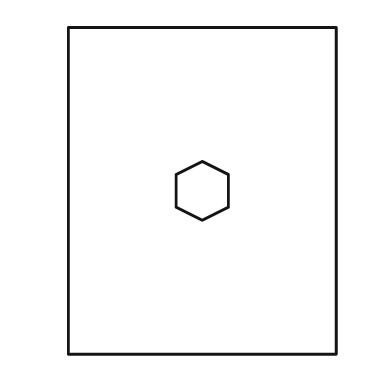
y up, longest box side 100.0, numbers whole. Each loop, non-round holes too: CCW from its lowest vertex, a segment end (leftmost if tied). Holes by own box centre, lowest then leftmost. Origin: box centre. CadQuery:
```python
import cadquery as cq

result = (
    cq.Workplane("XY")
    .moveTo(-41.0, -50.0)
    .lineTo(41.0, -50.0)
    .lineTo(41.0, 50.0)
    .lineTo(-41.0, 50.0)
    .close()
    .moveTo(0.0, -9.0)
    .lineTo(8.0, -5.0)
    .lineTo(8.0, 5.0)
    .lineTo(0.0, 9.0)
    .lineTo(-8.0, 5.0)
    .lineTo(-8.0, -5.0)
    .close()
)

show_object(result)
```